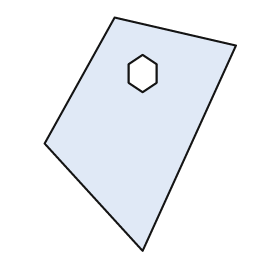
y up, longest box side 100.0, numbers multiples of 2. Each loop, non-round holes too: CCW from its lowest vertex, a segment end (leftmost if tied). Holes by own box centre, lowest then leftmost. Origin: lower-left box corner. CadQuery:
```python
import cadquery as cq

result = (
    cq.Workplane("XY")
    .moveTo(42.0, 0.0)
    .lineTo(82.0, 88.0)
    .lineTo(30.0, 100.0)
    .lineTo(0.0, 46.0)
    .close()
    .moveTo(42.0, 68.0)
    .lineTo(48.0, 72.0)
    .lineTo(48.0, 80.0)
    .lineTo(42.0, 84.0)
    .lineTo(36.0, 80.0)
    .lineTo(36.0, 72.0)
    .close()
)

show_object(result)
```